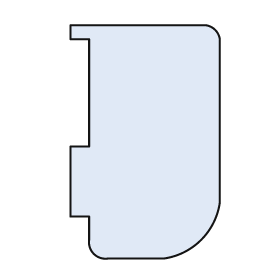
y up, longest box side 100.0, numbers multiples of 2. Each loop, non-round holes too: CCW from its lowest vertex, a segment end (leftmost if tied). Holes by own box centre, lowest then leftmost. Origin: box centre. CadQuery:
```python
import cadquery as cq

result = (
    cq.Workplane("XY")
    .moveTo(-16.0, -50.0)
    .lineTo(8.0, -50.0)
    .threePointArc((24.0, -42.0), (32.0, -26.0))
    .lineTo(32.0, 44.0)
    .threePointArc((30.0, 48.0), (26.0, 50.0))
    .lineTo(-32.0, 50.0)
    .lineTo(-32.0, 44.0)
    .lineTo(-24.0, 44.0)
    .lineTo(-24.0, -2.0)
    .lineTo(-32.0, -2.0)
    .lineTo(-32.0, -32.0)
    .lineTo(-24.0, -32.0)
    .lineTo(-24.0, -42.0)
    .threePointArc((-22.0, -48.0), (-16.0, -50.0))
    .close()
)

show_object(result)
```